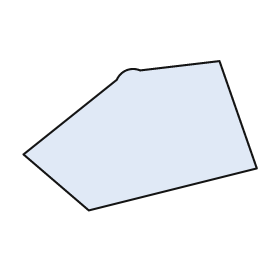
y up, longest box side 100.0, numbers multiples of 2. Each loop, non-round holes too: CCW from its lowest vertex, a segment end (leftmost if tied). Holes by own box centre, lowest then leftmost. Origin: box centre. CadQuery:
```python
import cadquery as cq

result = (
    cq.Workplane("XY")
    .moveTo(-22.0, -32.0)
    .lineTo(50.0, -14.0)
    .lineTo(34.0, 32.0)
    .lineTo(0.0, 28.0)
    .threePointArc((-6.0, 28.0), (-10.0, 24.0))
    .lineTo(-50.0, -8.0)
    .close()
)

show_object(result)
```